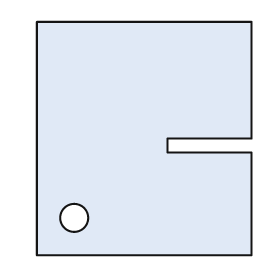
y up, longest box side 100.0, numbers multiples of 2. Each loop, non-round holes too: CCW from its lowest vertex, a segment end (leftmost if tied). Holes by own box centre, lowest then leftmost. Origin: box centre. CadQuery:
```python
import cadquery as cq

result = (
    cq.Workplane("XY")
    .moveTo(-46.0, -50.0)
    .lineTo(46.0, -50.0)
    .lineTo(46.0, -6.0)
    .lineTo(10.0, -6.0)
    .lineTo(10.0, 0.0)
    .lineTo(46.0, 0.0)
    .lineTo(46.0, 50.0)
    .lineTo(-46.0, 50.0)
    .close()
    .moveTo(-30.0, -34.0)
    .circle(6.0)
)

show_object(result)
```